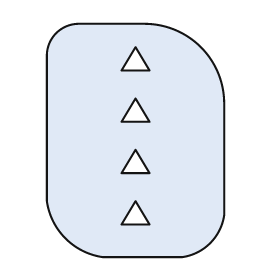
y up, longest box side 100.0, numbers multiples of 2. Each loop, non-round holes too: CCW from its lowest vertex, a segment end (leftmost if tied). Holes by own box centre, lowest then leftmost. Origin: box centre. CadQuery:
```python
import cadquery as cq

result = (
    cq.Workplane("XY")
    .moveTo(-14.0, -50.0)
    .lineTo(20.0, -50.0)
    .threePointArc((32.0, -44.0), (38.0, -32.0))
    .lineTo(38.0, 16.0)
    .threePointArc((28.0, 40.0), (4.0, 50.0))
    .lineTo(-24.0, 50.0)
    .threePointArc((-34.0, 46.0), (-38.0, 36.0))
    .lineTo(-38.0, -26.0)
    .threePointArc((-30.0, -42.0), (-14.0, -50.0))
    .close()
    .moveTo(-6.0, -36.0)
    .lineTo(6.0, -36.0)
    .lineTo(0.0, -26.0)
    .close()
    .moveTo(-6.0, -14.0)
    .lineTo(6.0, -14.0)
    .lineTo(0.0, -4.0)
    .close()
    .moveTo(-6.0, 8.0)
    .lineTo(6.0, 8.0)
    .lineTo(0.0, 18.0)
    .close()
    .moveTo(-6.0, 30.0)
    .lineTo(6.0, 30.0)
    .lineTo(0.0, 40.0)
    .close()
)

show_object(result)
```